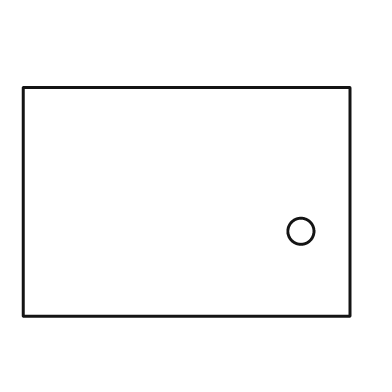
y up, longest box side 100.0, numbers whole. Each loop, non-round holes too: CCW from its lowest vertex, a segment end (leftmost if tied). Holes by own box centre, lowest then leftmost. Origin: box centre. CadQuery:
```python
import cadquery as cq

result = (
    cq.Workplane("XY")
    .moveTo(-50.0, -35.0)
    .lineTo(50.0, -35.0)
    .lineTo(50.0, 35.0)
    .lineTo(-50.0, 35.0)
    .close()
    .moveTo(35.0, -9.0)
    .circle(4.0)
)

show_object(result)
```